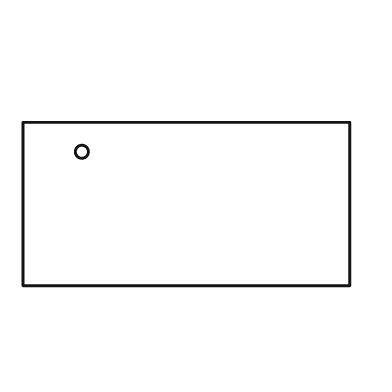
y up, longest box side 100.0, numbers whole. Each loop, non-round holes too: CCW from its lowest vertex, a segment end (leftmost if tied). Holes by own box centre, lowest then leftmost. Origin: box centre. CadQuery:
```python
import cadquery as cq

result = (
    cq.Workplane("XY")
    .moveTo(-50.0, -25.0)
    .lineTo(50.0, -25.0)
    .lineTo(50.0, 25.0)
    .lineTo(-50.0, 25.0)
    .close()
    .moveTo(-32.0, 16.0)
    .circle(2.0)
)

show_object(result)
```